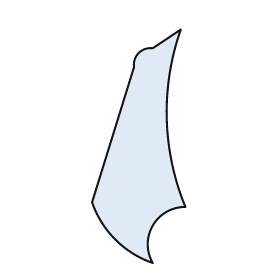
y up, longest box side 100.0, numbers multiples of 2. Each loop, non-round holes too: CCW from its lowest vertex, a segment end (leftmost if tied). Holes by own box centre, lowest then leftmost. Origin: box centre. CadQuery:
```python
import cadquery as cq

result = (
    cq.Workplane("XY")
    .moveTo(6.0, -50.0)
    .threePointArc((6.0, -34.0), (20.0, -26.0))
    .threePointArc((12.0, 12.0), (18.0, 50.0))
    .lineTo(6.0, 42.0)
    .threePointArc((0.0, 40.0), (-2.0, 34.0))
    .lineTo(-20.0, -24.0)
    .threePointArc((-10.0, -40.0), (6.0, -50.0))
    .close()
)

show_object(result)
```